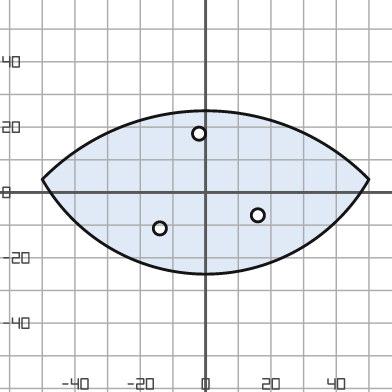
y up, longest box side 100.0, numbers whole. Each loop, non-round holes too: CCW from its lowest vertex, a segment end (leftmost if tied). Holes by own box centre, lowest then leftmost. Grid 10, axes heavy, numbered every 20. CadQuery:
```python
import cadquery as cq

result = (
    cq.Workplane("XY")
    .moveTo(-50.0, 4.0)
    .threePointArc((0.0, -25.0), (50.0, 4.0))
    .threePointArc((0.0, 25.0), (-50.0, 4.0))
    .close()
    .moveTo(-14.0, -11.0)
    .circle(2.0)
    .moveTo(16.0, -7.0)
    .circle(2.0)
    .moveTo(-2.0, 18.0)
    .circle(2.0)
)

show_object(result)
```